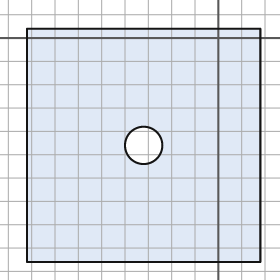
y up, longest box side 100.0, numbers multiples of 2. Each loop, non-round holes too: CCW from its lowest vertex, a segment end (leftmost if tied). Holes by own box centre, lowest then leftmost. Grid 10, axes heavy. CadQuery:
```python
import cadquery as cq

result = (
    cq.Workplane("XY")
    .moveTo(-82.0, -96.0)
    .lineTo(18.0, -96.0)
    .lineTo(18.0, 4.0)
    .lineTo(-82.0, 4.0)
    .close()
    .moveTo(-32.0, -46.0)
    .circle(8.0)
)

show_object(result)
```